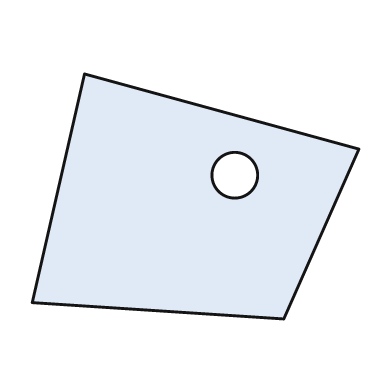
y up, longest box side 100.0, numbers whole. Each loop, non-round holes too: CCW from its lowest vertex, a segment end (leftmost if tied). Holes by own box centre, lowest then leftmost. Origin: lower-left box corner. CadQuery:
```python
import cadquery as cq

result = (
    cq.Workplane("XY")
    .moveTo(77.0, 0.0)
    .lineTo(100.0, 52.0)
    .lineTo(16.0, 75.0)
    .lineTo(0.0, 5.0)
    .close()
    .moveTo(62.0, 44.0)
    .circle(7.0)
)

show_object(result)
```